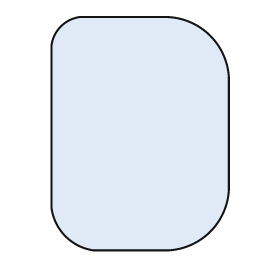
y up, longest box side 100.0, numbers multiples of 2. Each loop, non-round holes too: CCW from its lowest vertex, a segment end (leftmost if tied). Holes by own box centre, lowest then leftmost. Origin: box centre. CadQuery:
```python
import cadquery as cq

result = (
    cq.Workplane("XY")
    .moveTo(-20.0, -50.0)
    .lineTo(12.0, -50.0)
    .threePointArc((30.0, -42.0), (38.0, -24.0))
    .lineTo(38.0, 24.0)
    .threePointArc((30.0, 42.0), (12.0, 50.0))
    .lineTo(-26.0, 50.0)
    .threePointArc((-34.0, 46.0), (-38.0, 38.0))
    .lineTo(-38.0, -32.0)
    .threePointArc((-32.0, -44.0), (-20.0, -50.0))
    .close()
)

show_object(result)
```